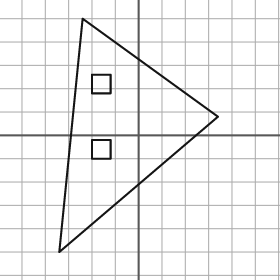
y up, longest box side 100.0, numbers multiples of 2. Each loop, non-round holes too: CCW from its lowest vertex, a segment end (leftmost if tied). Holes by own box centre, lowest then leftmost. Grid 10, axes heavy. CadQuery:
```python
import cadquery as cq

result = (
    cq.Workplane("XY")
    .moveTo(-34.0, -50.0)
    .lineTo(34.0, 8.0)
    .lineTo(-24.0, 50.0)
    .close()
    .moveTo(-20.0, -10.0)
    .lineTo(-12.0, -10.0)
    .lineTo(-12.0, -2.0)
    .lineTo(-20.0, -2.0)
    .close()
    .moveTo(-20.0, 18.0)
    .lineTo(-12.0, 18.0)
    .lineTo(-12.0, 26.0)
    .lineTo(-20.0, 26.0)
    .close()
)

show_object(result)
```